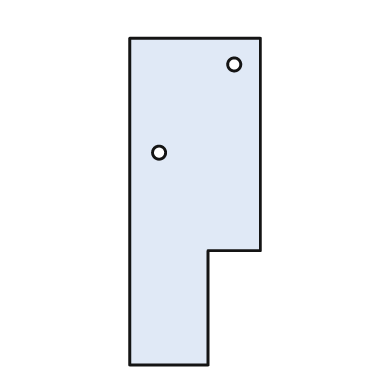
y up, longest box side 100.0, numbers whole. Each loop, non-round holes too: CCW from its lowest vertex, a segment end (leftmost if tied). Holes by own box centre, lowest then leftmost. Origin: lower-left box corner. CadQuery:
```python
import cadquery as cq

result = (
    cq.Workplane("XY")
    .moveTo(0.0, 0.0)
    .lineTo(24.0, 0.0)
    .lineTo(24.0, 35.0)
    .lineTo(40.0, 35.0)
    .lineTo(40.0, 100.0)
    .lineTo(0.0, 100.0)
    .close()
    .moveTo(9.0, 65.0)
    .circle(2.0)
    .moveTo(32.0, 92.0)
    .circle(2.0)
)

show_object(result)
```